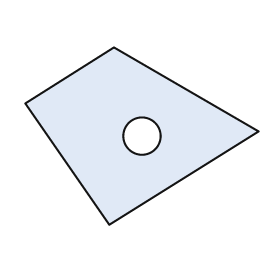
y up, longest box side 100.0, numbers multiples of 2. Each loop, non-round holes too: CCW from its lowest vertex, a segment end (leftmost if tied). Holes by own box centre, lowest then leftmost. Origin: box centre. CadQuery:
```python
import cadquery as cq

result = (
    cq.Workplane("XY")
    .moveTo(-14.0, -38.0)
    .lineTo(50.0, 2.0)
    .lineTo(-12.0, 38.0)
    .lineTo(-50.0, 14.0)
    .close()
    .moveTo(0.0, 0.0)
    .circle(8.0)
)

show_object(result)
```